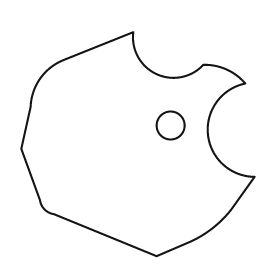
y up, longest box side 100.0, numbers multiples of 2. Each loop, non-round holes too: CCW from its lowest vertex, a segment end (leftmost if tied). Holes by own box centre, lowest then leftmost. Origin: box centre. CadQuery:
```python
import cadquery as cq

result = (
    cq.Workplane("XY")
    .moveTo(8.0, -48.0)
    .lineTo(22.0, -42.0)
    .threePointArc((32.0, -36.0), (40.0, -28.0))
    .lineTo(50.0, -14.0)
    .threePointArc((30.0, 4.0), (46.0, 26.0))
    .threePointArc((38.0, 32.0), (28.0, 34.0))
    .threePointArc((8.0, 30.0), (-2.0, 48.0))
    .lineTo(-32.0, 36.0)
    .threePointArc((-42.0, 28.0), (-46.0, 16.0))
    .lineTo(-50.0, -2.0)
    .lineTo(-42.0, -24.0)
    .threePointArc((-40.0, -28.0), (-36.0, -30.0))
    .close()
    .moveTo(14.0, 8.0)
    .circle(6.0)
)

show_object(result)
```